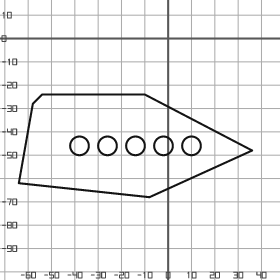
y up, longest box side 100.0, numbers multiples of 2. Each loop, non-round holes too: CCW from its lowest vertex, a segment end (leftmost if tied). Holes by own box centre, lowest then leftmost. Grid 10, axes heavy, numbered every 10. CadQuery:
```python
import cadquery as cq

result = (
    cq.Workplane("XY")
    .moveTo(-8.0, -68.0)
    .lineTo(36.0, -48.0)
    .lineTo(-10.0, -24.0)
    .lineTo(-54.0, -24.0)
    .lineTo(-58.0, -28.0)
    .lineTo(-64.0, -62.0)
    .close()
    .moveTo(-38.0, -46.0)
    .circle(4.0)
    .moveTo(-26.0, -46.0)
    .circle(4.0)
    .moveTo(-14.0, -46.0)
    .circle(4.0)
    .moveTo(-2.0, -46.0)
    .circle(4.0)
    .moveTo(10.0, -46.0)
    .circle(4.0)
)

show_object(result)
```